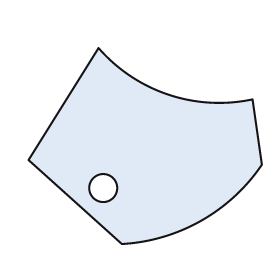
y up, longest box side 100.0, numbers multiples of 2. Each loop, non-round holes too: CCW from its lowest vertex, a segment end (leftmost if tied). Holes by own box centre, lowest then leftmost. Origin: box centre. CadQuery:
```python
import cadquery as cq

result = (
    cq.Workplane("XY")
    .moveTo(-10.0, -42.0)
    .threePointArc((24.0, -32.0), (50.0, -8.0))
    .lineTo(46.0, 20.0)
    .threePointArc((10.0, 22.0), (-20.0, 42.0))
    .lineTo(-50.0, -6.0)
    .close()
    .moveTo(-18.0, -18.0)
    .circle(6.0)
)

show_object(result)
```